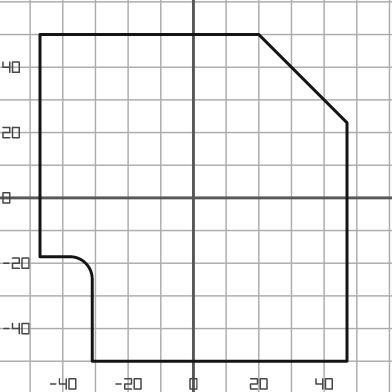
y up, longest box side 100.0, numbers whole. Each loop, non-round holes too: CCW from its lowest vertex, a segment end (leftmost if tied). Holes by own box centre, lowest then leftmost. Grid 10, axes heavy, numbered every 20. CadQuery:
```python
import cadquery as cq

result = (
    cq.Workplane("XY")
    .moveTo(-31.0, -50.0)
    .lineTo(47.0, -50.0)
    .lineTo(47.0, 23.0)
    .lineTo(20.0, 50.0)
    .lineTo(-47.0, 50.0)
    .lineTo(-47.0, -18.0)
    .lineTo(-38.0, -18.0)
    .threePointArc((-33.0, -20.0), (-31.0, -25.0))
    .close()
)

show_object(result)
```